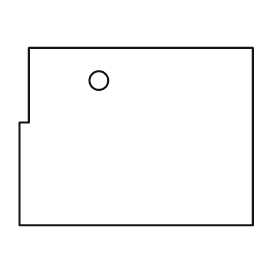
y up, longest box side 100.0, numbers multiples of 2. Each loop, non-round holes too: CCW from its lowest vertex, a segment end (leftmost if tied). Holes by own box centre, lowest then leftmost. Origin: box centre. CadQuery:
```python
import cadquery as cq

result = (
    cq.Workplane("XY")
    .moveTo(-50.0, -38.0)
    .lineTo(50.0, -38.0)
    .lineTo(50.0, 38.0)
    .lineTo(-46.0, 38.0)
    .lineTo(-46.0, 6.0)
    .lineTo(-50.0, 6.0)
    .close()
    .moveTo(-16.0, 24.0)
    .circle(4.0)
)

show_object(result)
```